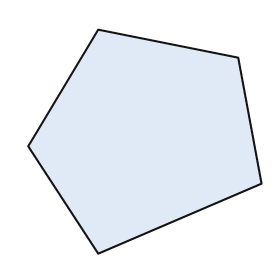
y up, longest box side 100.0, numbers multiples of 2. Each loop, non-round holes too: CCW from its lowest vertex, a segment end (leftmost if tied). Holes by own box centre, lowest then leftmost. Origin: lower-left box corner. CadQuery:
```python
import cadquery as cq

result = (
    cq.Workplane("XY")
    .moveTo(30.0, 0.0)
    .lineTo(100.0, 30.0)
    .lineTo(90.0, 84.0)
    .lineTo(30.0, 96.0)
    .lineTo(0.0, 46.0)
    .close()
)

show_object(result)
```